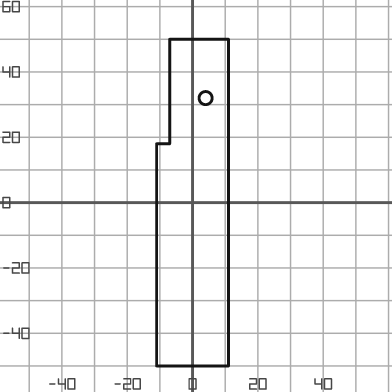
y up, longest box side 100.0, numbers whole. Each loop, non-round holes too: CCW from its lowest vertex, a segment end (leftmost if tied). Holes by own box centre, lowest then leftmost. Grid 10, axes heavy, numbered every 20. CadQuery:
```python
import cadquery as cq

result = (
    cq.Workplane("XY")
    .moveTo(-11.0, -50.0)
    .lineTo(11.0, -50.0)
    .lineTo(11.0, 50.0)
    .lineTo(-7.0, 50.0)
    .lineTo(-7.0, 18.0)
    .lineTo(-11.0, 18.0)
    .close()
    .moveTo(4.0, 32.0)
    .circle(2.0)
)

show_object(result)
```